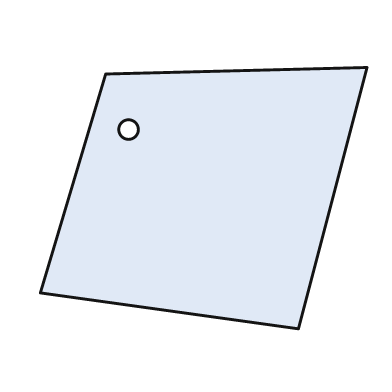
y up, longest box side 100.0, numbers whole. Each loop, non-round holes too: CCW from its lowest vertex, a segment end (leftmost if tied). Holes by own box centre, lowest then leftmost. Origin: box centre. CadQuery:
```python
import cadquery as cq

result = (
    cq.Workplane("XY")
    .moveTo(29.0, -40.0)
    .lineTo(50.0, 40.0)
    .lineTo(-30.0, 38.0)
    .lineTo(-50.0, -29.0)
    .close()
    .moveTo(-23.0, 21.0)
    .circle(3.0)
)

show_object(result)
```